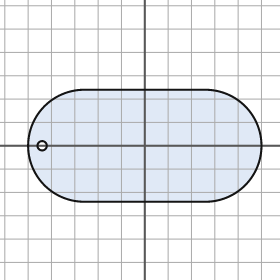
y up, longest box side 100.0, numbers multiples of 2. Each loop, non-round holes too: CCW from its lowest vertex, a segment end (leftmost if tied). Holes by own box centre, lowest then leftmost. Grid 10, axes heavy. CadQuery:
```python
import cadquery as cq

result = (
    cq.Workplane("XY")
    .moveTo(-26.0, -24.0)
    .lineTo(26.0, -24.0)
    .threePointArc((50.0, 0.0), (26.0, 24.0))
    .lineTo(-26.0, 24.0)
    .threePointArc((-50.0, 0.0), (-26.0, -24.0))
    .close()
    .moveTo(-44.0, 0.0)
    .circle(2.0)
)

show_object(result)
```